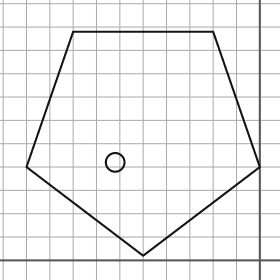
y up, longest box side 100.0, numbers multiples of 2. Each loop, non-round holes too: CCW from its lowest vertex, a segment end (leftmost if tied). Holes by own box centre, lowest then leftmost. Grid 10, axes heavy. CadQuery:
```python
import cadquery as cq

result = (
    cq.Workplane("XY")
    .moveTo(-50.0, 2.0)
    .lineTo(0.0, 40.0)
    .lineTo(-20.0, 98.0)
    .lineTo(-80.0, 98.0)
    .lineTo(-100.0, 40.0)
    .close()
    .moveTo(-62.0, 42.0)
    .circle(4.0)
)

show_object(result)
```